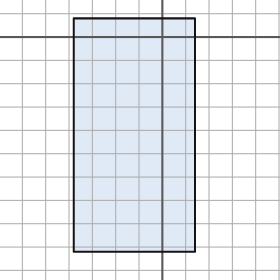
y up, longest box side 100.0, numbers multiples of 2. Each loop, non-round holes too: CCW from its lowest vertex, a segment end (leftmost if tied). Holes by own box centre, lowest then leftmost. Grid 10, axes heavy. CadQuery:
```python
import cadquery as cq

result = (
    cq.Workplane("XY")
    .moveTo(-38.0, -92.0)
    .lineTo(14.0, -92.0)
    .lineTo(14.0, 8.0)
    .lineTo(-38.0, 8.0)
    .close()
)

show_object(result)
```